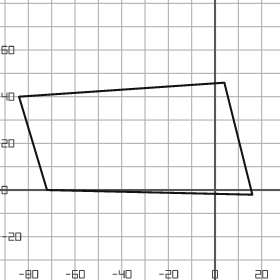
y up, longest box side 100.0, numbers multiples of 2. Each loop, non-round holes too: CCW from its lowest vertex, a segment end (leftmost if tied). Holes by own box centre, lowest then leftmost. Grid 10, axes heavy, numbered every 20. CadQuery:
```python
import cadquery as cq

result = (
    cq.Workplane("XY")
    .moveTo(16.0, -2.0)
    .lineTo(4.0, 46.0)
    .lineTo(-84.0, 40.0)
    .lineTo(-72.0, 0.0)
    .close()
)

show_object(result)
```